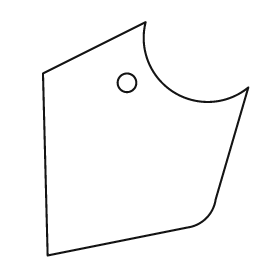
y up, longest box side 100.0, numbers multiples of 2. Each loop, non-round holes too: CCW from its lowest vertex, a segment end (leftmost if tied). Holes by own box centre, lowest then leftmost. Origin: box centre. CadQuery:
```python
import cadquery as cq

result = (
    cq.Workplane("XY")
    .moveTo(-42.0, -50.0)
    .lineTo(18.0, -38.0)
    .threePointArc((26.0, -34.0), (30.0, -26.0))
    .lineTo(44.0, 22.0)
    .threePointArc((12.0, 20.0), (0.0, 50.0))
    .lineTo(-44.0, 28.0)
    .close()
    .moveTo(-8.0, 24.0)
    .circle(4.0)
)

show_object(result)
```